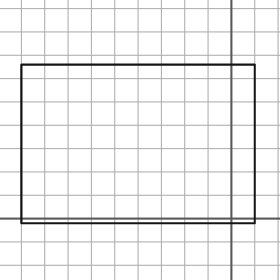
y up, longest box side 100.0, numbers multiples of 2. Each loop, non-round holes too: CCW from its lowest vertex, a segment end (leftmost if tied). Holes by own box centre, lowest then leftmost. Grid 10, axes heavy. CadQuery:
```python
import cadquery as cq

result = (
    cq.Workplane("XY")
    .moveTo(-90.0, -2.0)
    .lineTo(10.0, -2.0)
    .lineTo(10.0, 66.0)
    .lineTo(-90.0, 66.0)
    .close()
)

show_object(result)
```